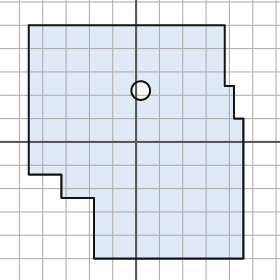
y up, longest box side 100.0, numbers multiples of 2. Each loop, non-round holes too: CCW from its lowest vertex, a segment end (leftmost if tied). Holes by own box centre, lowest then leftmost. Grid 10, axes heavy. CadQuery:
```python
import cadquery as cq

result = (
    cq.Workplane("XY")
    .moveTo(-18.0, -50.0)
    .lineTo(46.0, -50.0)
    .lineTo(46.0, 10.0)
    .lineTo(42.0, 10.0)
    .lineTo(42.0, 24.0)
    .lineTo(38.0, 24.0)
    .lineTo(38.0, 50.0)
    .lineTo(-46.0, 50.0)
    .lineTo(-46.0, -14.0)
    .lineTo(-32.0, -14.0)
    .lineTo(-32.0, -24.0)
    .lineTo(-18.0, -24.0)
    .close()
    .moveTo(2.0, 22.0)
    .circle(4.0)
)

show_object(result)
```